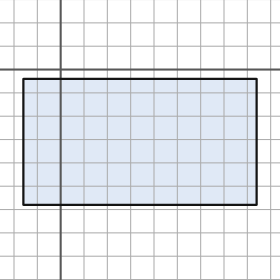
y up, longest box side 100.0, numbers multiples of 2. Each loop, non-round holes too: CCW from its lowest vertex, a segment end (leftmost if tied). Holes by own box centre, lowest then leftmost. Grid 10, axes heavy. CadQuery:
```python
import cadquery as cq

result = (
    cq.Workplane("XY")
    .moveTo(-16.0, -58.0)
    .lineTo(84.0, -58.0)
    .lineTo(84.0, -4.0)
    .lineTo(-16.0, -4.0)
    .close()
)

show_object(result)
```